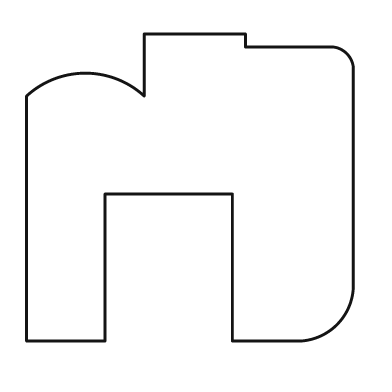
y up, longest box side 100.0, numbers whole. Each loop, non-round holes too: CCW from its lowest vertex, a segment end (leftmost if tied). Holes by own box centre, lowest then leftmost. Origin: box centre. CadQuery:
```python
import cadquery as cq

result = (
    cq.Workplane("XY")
    .moveTo(-50.0, -47.0)
    .lineTo(-26.0, -47.0)
    .lineTo(-26.0, -2.0)
    .lineTo(13.0, -2.0)
    .lineTo(13.0, -47.0)
    .lineTo(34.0, -47.0)
    .threePointArc((45.0, -42.0), (50.0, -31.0))
    .lineTo(50.0, 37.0)
    .threePointArc((48.0, 41.0), (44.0, 43.0))
    .lineTo(17.0, 43.0)
    .lineTo(17.0, 47.0)
    .lineTo(-14.0, 47.0)
    .lineTo(-14.0, 28.0)
    .threePointArc((-32.0, 35.0), (-50.0, 28.0))
    .close()
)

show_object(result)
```